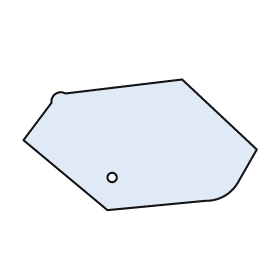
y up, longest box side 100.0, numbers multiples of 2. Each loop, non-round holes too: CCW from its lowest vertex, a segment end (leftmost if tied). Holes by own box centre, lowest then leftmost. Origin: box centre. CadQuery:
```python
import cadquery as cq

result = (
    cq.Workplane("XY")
    .moveTo(-14.0, -28.0)
    .lineTo(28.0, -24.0)
    .threePointArc((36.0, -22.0), (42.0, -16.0))
    .lineTo(50.0, -2.0)
    .lineTo(18.0, 28.0)
    .lineTo(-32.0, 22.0)
    .threePointArc((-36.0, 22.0), (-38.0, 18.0))
    .lineTo(-50.0, 2.0)
    .close()
    .moveTo(-12.0, -14.0)
    .circle(2.0)
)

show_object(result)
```